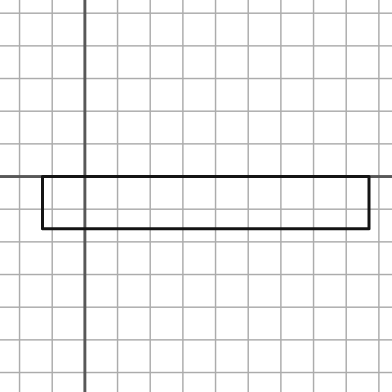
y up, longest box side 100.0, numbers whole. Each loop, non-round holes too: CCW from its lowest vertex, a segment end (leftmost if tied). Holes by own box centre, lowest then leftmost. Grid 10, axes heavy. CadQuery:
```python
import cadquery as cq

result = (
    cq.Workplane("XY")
    .moveTo(-13.0, -16.0)
    .lineTo(87.0, -16.0)
    .lineTo(87.0, 0.0)
    .lineTo(-13.0, 0.0)
    .close()
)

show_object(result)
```